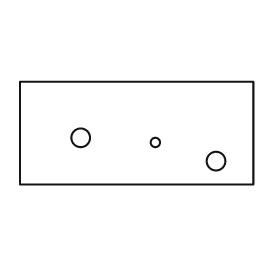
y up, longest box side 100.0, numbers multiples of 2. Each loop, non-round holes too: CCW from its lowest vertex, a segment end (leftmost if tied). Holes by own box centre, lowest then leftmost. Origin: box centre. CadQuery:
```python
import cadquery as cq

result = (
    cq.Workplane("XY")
    .moveTo(-50.0, -22.0)
    .lineTo(50.0, -22.0)
    .lineTo(50.0, 22.0)
    .lineTo(-50.0, 22.0)
    .close()
    .moveTo(34.0, -12.0)
    .circle(4.0)
    .moveTo(8.0, -4.0)
    .circle(2.0)
    .moveTo(-24.0, -2.0)
    .circle(4.0)
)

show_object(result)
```